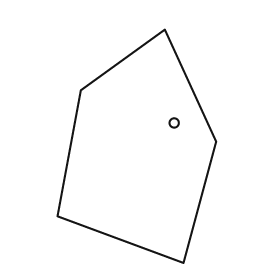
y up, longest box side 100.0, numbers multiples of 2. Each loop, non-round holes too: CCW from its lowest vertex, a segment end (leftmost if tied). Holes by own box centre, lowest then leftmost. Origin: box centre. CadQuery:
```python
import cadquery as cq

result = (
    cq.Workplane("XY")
    .moveTo(20.0, -50.0)
    .lineTo(34.0, 2.0)
    .lineTo(12.0, 50.0)
    .lineTo(-24.0, 24.0)
    .lineTo(-34.0, -30.0)
    .close()
    .moveTo(16.0, 10.0)
    .circle(2.0)
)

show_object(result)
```